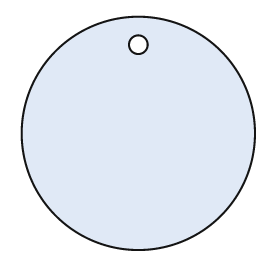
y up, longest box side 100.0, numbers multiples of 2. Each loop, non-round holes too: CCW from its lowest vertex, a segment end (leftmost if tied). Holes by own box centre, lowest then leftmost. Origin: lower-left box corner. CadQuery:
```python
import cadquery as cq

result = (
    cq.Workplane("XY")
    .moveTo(50.0, 50.0)
    .circle(50.0)
    .moveTo(50.0, 88.0)
    .circle(4.0)
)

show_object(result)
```